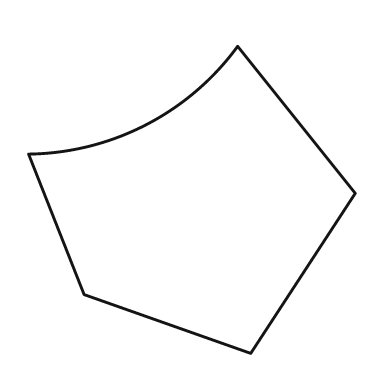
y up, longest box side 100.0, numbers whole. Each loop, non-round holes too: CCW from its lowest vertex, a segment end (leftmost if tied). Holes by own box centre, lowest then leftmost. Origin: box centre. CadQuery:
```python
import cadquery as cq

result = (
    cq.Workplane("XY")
    .moveTo(18.0, -47.0)
    .lineTo(50.0, 2.0)
    .lineTo(14.0, 47.0)
    .threePointArc((-14.0, 23.0), (-50.0, 14.0))
    .lineTo(-33.0, -29.0)
    .close()
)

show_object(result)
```